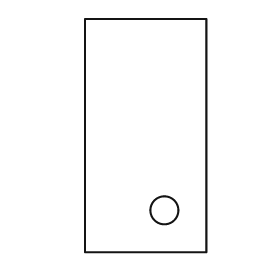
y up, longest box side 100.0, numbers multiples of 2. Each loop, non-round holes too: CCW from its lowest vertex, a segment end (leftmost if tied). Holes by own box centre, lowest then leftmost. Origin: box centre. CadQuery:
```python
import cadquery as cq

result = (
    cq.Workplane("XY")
    .moveTo(-26.0, -50.0)
    .lineTo(26.0, -50.0)
    .lineTo(26.0, 50.0)
    .lineTo(-26.0, 50.0)
    .close()
    .moveTo(8.0, -32.0)
    .circle(6.0)
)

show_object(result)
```